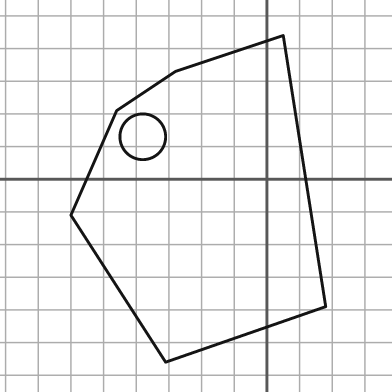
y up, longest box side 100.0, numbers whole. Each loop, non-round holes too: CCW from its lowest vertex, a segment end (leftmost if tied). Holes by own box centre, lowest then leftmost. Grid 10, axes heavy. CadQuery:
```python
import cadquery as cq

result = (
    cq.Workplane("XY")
    .moveTo(-31.0, -56.0)
    .lineTo(18.0, -39.0)
    .lineTo(5.0, 44.0)
    .lineTo(-28.0, 33.0)
    .lineTo(-46.0, 21.0)
    .lineTo(-60.0, -11.0)
    .close()
    .moveTo(-38.0, 13.0)
    .circle(7.0)
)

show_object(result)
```